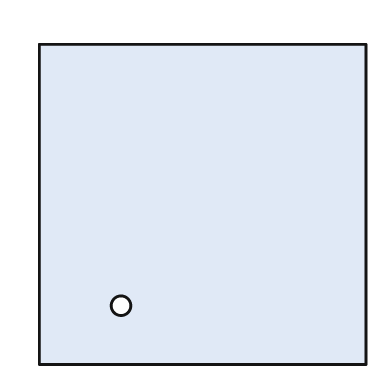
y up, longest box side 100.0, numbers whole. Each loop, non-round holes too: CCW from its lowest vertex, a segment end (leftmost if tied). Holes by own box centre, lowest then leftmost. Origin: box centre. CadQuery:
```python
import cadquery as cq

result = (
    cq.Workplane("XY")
    .moveTo(-50.0, -49.0)
    .lineTo(50.0, -49.0)
    .lineTo(50.0, 49.0)
    .lineTo(-50.0, 49.0)
    .close()
    .moveTo(-25.0, -31.0)
    .circle(3.0)
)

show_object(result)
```